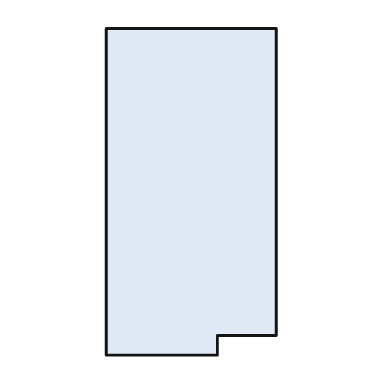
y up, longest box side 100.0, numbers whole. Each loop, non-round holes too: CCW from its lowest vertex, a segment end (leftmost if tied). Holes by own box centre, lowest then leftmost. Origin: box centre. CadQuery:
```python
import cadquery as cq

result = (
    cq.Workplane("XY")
    .moveTo(-26.0, -50.0)
    .lineTo(8.0, -50.0)
    .lineTo(8.0, -44.0)
    .lineTo(26.0, -44.0)
    .lineTo(26.0, 50.0)
    .lineTo(-26.0, 50.0)
    .close()
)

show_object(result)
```